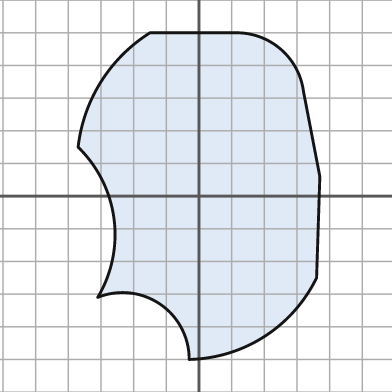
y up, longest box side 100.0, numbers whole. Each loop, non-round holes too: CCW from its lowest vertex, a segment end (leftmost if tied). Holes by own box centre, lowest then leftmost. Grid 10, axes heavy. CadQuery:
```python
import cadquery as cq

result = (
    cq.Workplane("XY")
    .moveTo(-3.0, -50.0)
    .threePointArc((20.0, -43.0), (36.0, -25.0))
    .lineTo(37.0, 6.0)
    .lineTo(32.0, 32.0)
    .threePointArc((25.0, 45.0), (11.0, 50.0))
    .lineTo(-15.0, 50.0)
    .threePointArc((-30.0, 35.0), (-37.0, 15.0))
    .threePointArc((-26.0, -7.0), (-31.0, -31.0))
    .threePointArc((-12.0, -33.0), (-3.0, -50.0))
    .close()
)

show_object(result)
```